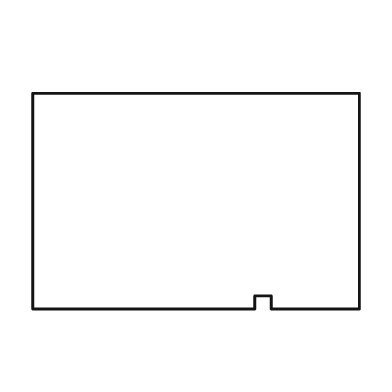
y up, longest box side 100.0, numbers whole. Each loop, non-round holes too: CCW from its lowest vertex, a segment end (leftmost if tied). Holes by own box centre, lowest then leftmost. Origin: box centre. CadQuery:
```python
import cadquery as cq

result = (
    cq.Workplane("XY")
    .moveTo(-50.0, -33.0)
    .lineTo(18.0, -33.0)
    .lineTo(18.0, -29.0)
    .lineTo(23.0, -29.0)
    .lineTo(23.0, -33.0)
    .lineTo(50.0, -33.0)
    .lineTo(50.0, 33.0)
    .lineTo(-50.0, 33.0)
    .close()
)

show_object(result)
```